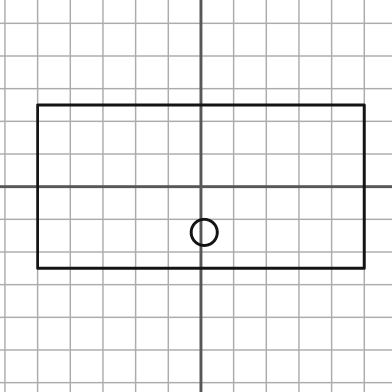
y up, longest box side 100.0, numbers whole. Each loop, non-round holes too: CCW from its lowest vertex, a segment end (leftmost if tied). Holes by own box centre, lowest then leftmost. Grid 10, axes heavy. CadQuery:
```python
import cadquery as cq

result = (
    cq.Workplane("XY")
    .moveTo(-50.0, -25.0)
    .lineTo(50.0, -25.0)
    .lineTo(50.0, 25.0)
    .lineTo(-50.0, 25.0)
    .close()
    .moveTo(1.0, -14.0)
    .circle(4.0)
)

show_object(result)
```